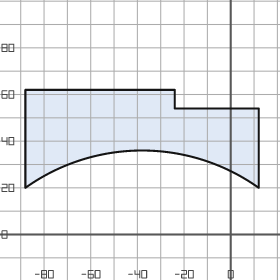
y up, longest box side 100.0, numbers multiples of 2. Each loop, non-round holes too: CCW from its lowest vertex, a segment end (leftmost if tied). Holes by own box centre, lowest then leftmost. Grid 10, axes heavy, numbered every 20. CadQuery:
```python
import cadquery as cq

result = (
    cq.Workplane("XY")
    .moveTo(-88.0, 20.0)
    .threePointArc((-38.0, 36.0), (12.0, 20.0))
    .lineTo(12.0, 54.0)
    .lineTo(-24.0, 54.0)
    .lineTo(-24.0, 62.0)
    .lineTo(-88.0, 62.0)
    .close()
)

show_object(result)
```